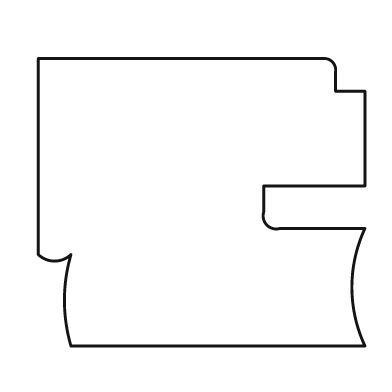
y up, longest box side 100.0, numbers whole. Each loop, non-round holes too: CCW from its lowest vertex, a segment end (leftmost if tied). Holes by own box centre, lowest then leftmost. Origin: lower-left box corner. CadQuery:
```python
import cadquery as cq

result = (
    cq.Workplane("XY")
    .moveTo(10.0, 0.0)
    .lineTo(100.0, 0.0)
    .threePointArc((96.0, 18.0), (100.0, 36.0))
    .lineTo(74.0, 36.0)
    .threePointArc((70.0, 37.0), (69.0, 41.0))
    .lineTo(69.0, 49.0)
    .lineTo(100.0, 49.0)
    .lineTo(100.0, 78.0)
    .lineTo(91.0, 78.0)
    .lineTo(91.0, 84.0)
    .threePointArc((90.0, 87.0), (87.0, 88.0))
    .lineTo(0.0, 88.0)
    .lineTo(0.0, 28.0)
    .threePointArc((5.0, 26.0), (10.0, 28.0))
    .threePointArc((8.0, 14.0), (10.0, 0.0))
    .close()
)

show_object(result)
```